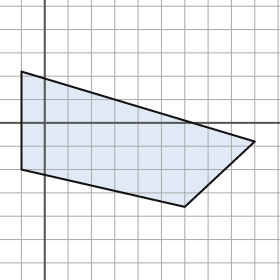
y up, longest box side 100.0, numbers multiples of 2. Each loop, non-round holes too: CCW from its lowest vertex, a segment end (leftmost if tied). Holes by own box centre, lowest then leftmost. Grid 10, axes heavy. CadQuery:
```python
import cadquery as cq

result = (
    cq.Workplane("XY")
    .moveTo(60.0, -36.0)
    .lineTo(90.0, -8.0)
    .lineTo(-10.0, 22.0)
    .lineTo(-10.0, -20.0)
    .close()
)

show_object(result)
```